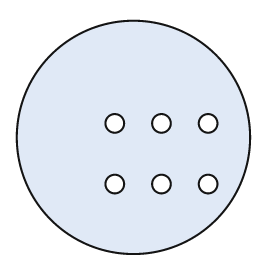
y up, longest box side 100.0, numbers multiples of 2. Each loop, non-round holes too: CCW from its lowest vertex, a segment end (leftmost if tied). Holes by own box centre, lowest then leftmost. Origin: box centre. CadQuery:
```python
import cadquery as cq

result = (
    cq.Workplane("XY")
    .moveTo(0.0, 0.0)
    .circle(50.0)
    .moveTo(-8.0, -20.0)
    .circle(4.0)
    .moveTo(12.0, -20.0)
    .circle(4.0)
    .moveTo(32.0, -20.0)
    .circle(4.0)
    .moveTo(-8.0, 6.0)
    .circle(4.0)
    .moveTo(12.0, 6.0)
    .circle(4.0)
    .moveTo(32.0, 6.0)
    .circle(4.0)
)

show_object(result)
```